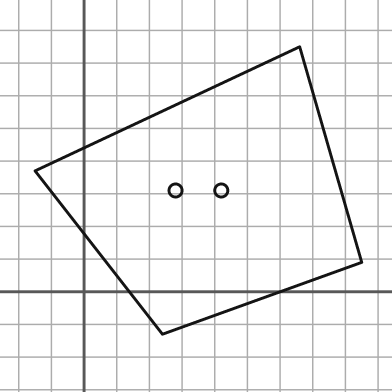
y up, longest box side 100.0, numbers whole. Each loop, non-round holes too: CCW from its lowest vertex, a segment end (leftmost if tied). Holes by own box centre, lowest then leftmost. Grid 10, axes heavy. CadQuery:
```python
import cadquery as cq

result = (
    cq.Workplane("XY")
    .moveTo(24.0, -13.0)
    .lineTo(85.0, 9.0)
    .lineTo(66.0, 75.0)
    .lineTo(-15.0, 37.0)
    .close()
    .moveTo(28.0, 31.0)
    .circle(2.0)
    .moveTo(42.0, 31.0)
    .circle(2.0)
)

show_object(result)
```